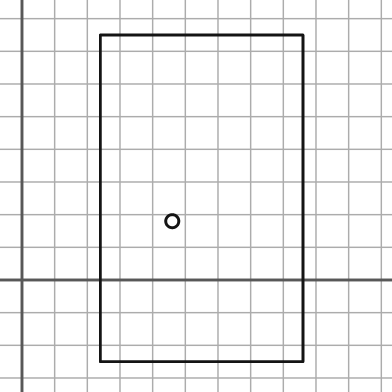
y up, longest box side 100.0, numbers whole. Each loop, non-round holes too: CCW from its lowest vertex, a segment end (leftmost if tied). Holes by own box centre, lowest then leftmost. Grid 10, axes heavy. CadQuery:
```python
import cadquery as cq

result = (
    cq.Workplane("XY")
    .moveTo(24.0, -25.0)
    .lineTo(86.0, -25.0)
    .lineTo(86.0, 75.0)
    .lineTo(24.0, 75.0)
    .close()
    .moveTo(46.0, 18.0)
    .circle(2.0)
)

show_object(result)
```